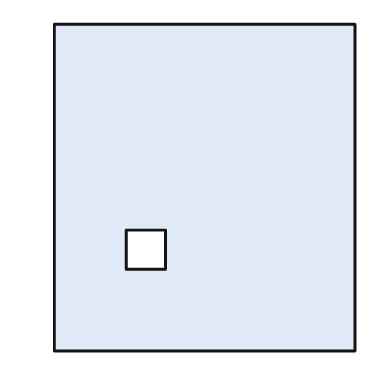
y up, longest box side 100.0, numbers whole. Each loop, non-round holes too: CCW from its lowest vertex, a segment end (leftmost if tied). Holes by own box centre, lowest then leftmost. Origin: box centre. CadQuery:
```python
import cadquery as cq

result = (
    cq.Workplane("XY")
    .moveTo(-46.0, -50.0)
    .lineTo(46.0, -50.0)
    .lineTo(46.0, 50.0)
    .lineTo(-46.0, 50.0)
    .close()
    .moveTo(-24.0, -25.0)
    .lineTo(-12.0, -25.0)
    .lineTo(-12.0, -13.0)
    .lineTo(-24.0, -13.0)
    .close()
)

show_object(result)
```